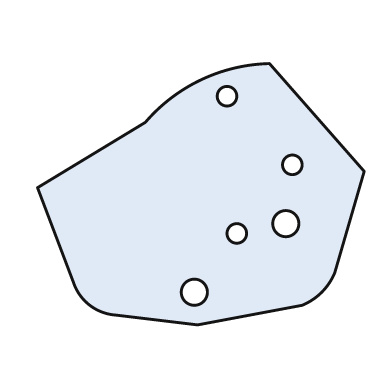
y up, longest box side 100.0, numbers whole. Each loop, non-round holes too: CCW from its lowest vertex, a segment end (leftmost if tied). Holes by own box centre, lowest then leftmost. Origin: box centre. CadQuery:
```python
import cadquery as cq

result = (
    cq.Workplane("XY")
    .moveTo(-1.0, -40.0)
    .lineTo(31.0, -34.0)
    .threePointArc((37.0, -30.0), (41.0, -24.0))
    .lineTo(50.0, 7.0)
    .lineTo(21.0, 40.0)
    .threePointArc((0.0, 35.0), (-17.0, 22.0))
    .lineTo(-50.0, 2.0)
    .lineTo(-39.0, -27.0)
    .threePointArc((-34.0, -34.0), (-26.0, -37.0))
    .close()
    .moveTo(-2.0, -30.0)
    .circle(4.0)
    .moveTo(11.0, -12.0)
    .circle(3.0)
    .moveTo(26.0, -9.0)
    .circle(4.0)
    .moveTo(28.0, 9.0)
    .circle(3.0)
    .moveTo(8.0, 30.0)
    .circle(3.0)
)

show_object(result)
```